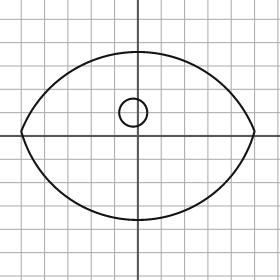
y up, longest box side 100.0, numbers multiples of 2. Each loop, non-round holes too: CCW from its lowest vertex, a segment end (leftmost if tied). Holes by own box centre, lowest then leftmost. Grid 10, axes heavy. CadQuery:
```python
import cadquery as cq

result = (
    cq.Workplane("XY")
    .moveTo(-50.0, 2.0)
    .threePointArc((0.0, -36.0), (50.0, 2.0))
    .threePointArc((0.0, 36.0), (-50.0, 2.0))
    .close()
    .moveTo(-2.0, 10.0)
    .circle(6.0)
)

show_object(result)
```